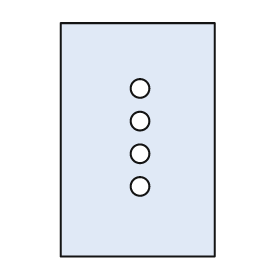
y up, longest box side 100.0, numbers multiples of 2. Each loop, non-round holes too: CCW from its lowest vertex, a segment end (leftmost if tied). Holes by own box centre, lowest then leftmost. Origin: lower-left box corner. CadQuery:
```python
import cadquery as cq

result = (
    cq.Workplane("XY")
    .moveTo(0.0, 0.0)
    .lineTo(66.0, 0.0)
    .lineTo(66.0, 100.0)
    .lineTo(0.0, 100.0)
    .close()
    .moveTo(34.0, 30.0)
    .circle(4.0)
    .moveTo(34.0, 44.0)
    .circle(4.0)
    .moveTo(34.0, 58.0)
    .circle(4.0)
    .moveTo(34.0, 72.0)
    .circle(4.0)
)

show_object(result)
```